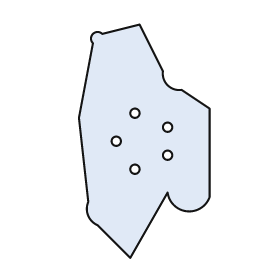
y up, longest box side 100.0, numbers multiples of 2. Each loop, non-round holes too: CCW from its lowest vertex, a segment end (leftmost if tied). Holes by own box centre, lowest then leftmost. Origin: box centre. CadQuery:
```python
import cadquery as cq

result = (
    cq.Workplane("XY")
    .moveTo(-6.0, -50.0)
    .lineTo(10.0, -22.0)
    .threePointArc((18.0, -30.0), (28.0, -24.0))
    .lineTo(28.0, 14.0)
    .lineTo(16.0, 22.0)
    .threePointArc((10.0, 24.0), (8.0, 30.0))
    .lineTo(-2.0, 50.0)
    .lineTo(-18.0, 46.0)
    .threePointArc((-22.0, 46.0), (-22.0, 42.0))
    .lineTo(-28.0, 10.0)
    .lineTo(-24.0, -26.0)
    .threePointArc((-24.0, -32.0), (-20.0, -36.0))
    .close()
    .moveTo(-4.0, -12.0)
    .circle(2.0)
    .moveTo(10.0, -6.0)
    .circle(2.0)
    .moveTo(-12.0, 0.0)
    .circle(2.0)
    .moveTo(10.0, 6.0)
    .circle(2.0)
    .moveTo(-4.0, 12.0)
    .circle(2.0)
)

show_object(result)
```